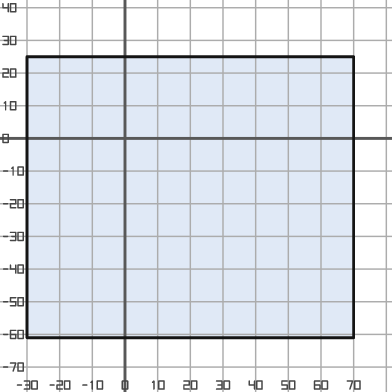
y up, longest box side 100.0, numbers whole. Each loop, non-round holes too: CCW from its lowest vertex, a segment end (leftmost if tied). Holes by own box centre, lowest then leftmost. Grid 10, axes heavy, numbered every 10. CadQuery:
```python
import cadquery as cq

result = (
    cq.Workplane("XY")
    .moveTo(-30.0, -61.0)
    .lineTo(70.0, -61.0)
    .lineTo(70.0, 25.0)
    .lineTo(-30.0, 25.0)
    .close()
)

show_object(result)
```